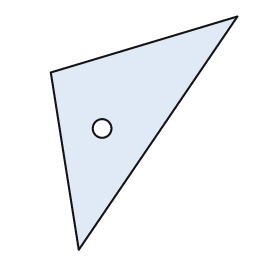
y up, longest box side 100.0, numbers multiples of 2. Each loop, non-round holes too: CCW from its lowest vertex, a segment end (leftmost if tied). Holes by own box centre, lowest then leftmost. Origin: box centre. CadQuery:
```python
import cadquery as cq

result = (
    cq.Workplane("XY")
    .moveTo(-28.0, -50.0)
    .lineTo(40.0, 50.0)
    .lineTo(-40.0, 26.0)
    .close()
    .moveTo(-18.0, 2.0)
    .circle(4.0)
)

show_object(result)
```